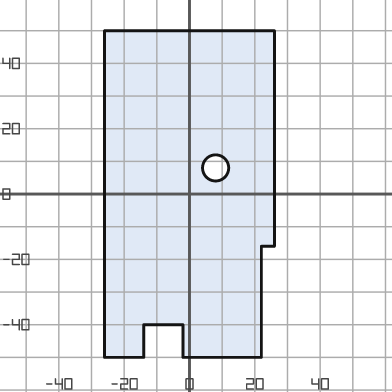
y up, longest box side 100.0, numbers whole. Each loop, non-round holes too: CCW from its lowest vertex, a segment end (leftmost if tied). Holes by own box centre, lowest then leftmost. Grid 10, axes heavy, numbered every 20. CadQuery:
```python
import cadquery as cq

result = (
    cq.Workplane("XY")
    .moveTo(-26.0, -50.0)
    .lineTo(-14.0, -50.0)
    .lineTo(-14.0, -40.0)
    .lineTo(-2.0, -40.0)
    .lineTo(-2.0, -50.0)
    .lineTo(22.0, -50.0)
    .lineTo(22.0, -16.0)
    .lineTo(26.0, -16.0)
    .lineTo(26.0, 50.0)
    .lineTo(-26.0, 50.0)
    .close()
    .moveTo(8.0, 8.0)
    .circle(4.0)
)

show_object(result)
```